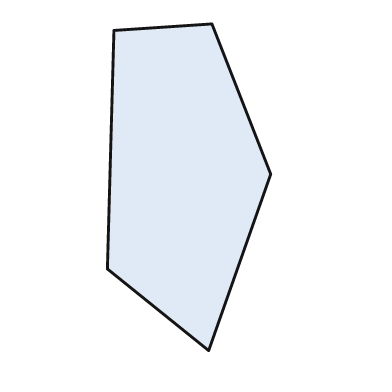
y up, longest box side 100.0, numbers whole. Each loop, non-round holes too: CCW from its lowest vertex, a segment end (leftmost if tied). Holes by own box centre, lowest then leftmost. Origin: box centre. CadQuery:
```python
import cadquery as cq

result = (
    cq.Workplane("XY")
    .moveTo(6.0, -50.0)
    .lineTo(25.0, 4.0)
    .lineTo(7.0, 50.0)
    .lineTo(-23.0, 48.0)
    .lineTo(-25.0, -25.0)
    .close()
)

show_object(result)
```